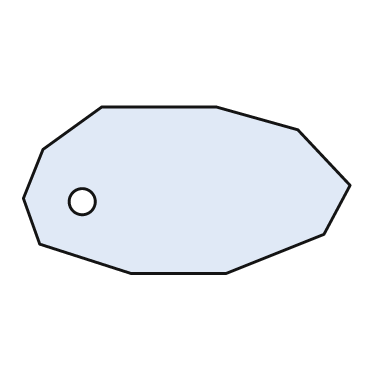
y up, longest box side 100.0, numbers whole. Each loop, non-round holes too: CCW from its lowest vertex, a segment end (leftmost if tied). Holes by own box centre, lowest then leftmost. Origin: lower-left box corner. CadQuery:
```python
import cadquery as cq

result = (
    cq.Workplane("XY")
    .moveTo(33.0, 0.0)
    .lineTo(62.0, 0.0)
    .lineTo(92.0, 12.0)
    .lineTo(100.0, 27.0)
    .lineTo(84.0, 44.0)
    .lineTo(59.0, 51.0)
    .lineTo(24.0, 51.0)
    .lineTo(6.0, 38.0)
    .lineTo(0.0, 23.0)
    .lineTo(5.0, 9.0)
    .close()
    .moveTo(18.0, 22.0)
    .circle(4.0)
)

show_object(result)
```